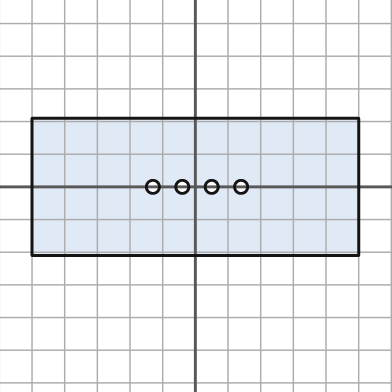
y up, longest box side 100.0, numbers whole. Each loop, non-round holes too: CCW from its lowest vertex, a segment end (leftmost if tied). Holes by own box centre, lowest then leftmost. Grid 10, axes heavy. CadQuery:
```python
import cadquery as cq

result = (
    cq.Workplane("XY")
    .moveTo(-50.0, -21.0)
    .lineTo(50.0, -21.0)
    .lineTo(50.0, 21.0)
    .lineTo(-50.0, 21.0)
    .close()
    .moveTo(-13.0, 0.0)
    .circle(2.0)
    .moveTo(-4.0, 0.0)
    .circle(2.0)
    .moveTo(5.0, 0.0)
    .circle(2.0)
    .moveTo(14.0, 0.0)
    .circle(2.0)
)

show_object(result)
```